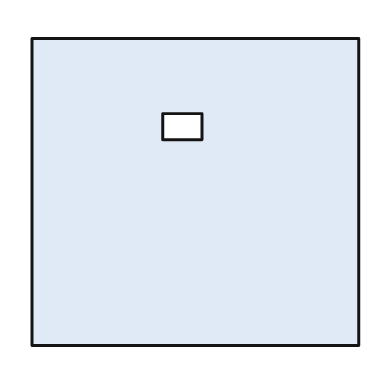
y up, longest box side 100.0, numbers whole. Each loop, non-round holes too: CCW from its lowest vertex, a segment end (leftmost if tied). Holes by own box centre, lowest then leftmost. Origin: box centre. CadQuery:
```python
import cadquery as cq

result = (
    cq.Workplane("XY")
    .moveTo(-50.0, -47.0)
    .lineTo(50.0, -47.0)
    .lineTo(50.0, 47.0)
    .lineTo(-50.0, 47.0)
    .close()
    .moveTo(-10.0, 16.0)
    .lineTo(2.0, 16.0)
    .lineTo(2.0, 24.0)
    .lineTo(-10.0, 24.0)
    .close()
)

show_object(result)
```